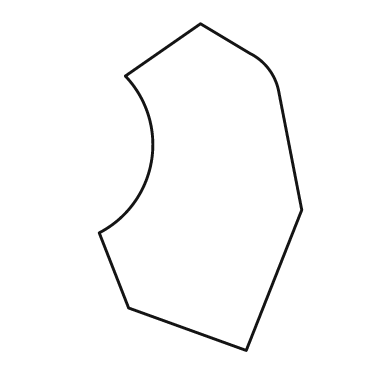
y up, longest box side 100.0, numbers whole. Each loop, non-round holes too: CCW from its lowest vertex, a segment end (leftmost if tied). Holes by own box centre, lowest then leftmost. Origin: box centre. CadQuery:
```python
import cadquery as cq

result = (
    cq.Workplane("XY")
    .moveTo(14.0, -50.0)
    .lineTo(31.0, -7.0)
    .lineTo(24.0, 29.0)
    .threePointArc((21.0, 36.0), (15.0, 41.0))
    .lineTo(0.0, 50.0)
    .lineTo(-23.0, 34.0)
    .threePointArc((-15.0, 8.0), (-31.0, -14.0))
    .lineTo(-22.0, -37.0)
    .close()
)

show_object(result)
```